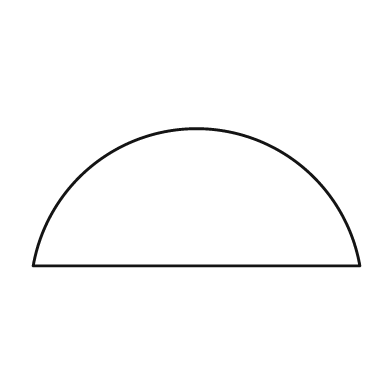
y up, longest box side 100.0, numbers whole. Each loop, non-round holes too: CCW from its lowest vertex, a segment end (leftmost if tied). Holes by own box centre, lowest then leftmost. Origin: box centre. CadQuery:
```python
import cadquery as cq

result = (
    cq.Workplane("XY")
    .moveTo(-50.0, -21.0)
    .lineTo(50.0, -21.0)
    .threePointArc((0.0, 21.0), (-50.0, -21.0))
    .close()
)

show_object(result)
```